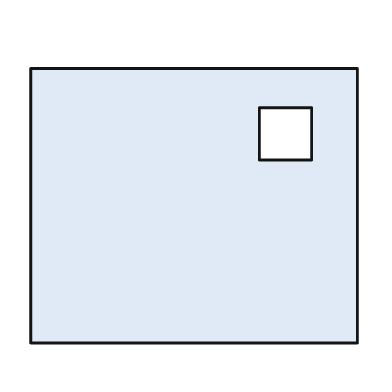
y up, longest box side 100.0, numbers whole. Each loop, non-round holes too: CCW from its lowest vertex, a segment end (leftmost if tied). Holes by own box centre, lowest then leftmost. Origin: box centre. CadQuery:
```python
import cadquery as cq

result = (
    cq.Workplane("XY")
    .moveTo(-50.0, -42.0)
    .lineTo(50.0, -42.0)
    .lineTo(50.0, 42.0)
    .lineTo(-50.0, 42.0)
    .close()
    .moveTo(20.0, 14.0)
    .lineTo(36.0, 14.0)
    .lineTo(36.0, 30.0)
    .lineTo(20.0, 30.0)
    .close()
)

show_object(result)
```